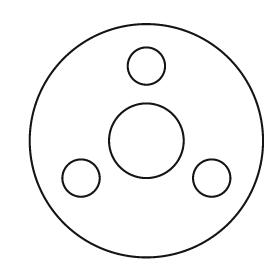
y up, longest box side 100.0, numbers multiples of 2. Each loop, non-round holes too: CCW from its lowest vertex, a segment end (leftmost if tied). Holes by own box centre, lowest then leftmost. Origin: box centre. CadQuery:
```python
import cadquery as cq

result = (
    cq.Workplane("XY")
    .moveTo(0.0, 0.0)
    .circle(50.0)
    .moveTo(-28.0, -16.0)
    .circle(8.0)
    .moveTo(28.0, -16.0)
    .circle(8.0)
    .moveTo(0.0, 0.0)
    .circle(16.0)
    .moveTo(0.0, 32.0)
    .circle(8.0)
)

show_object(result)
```